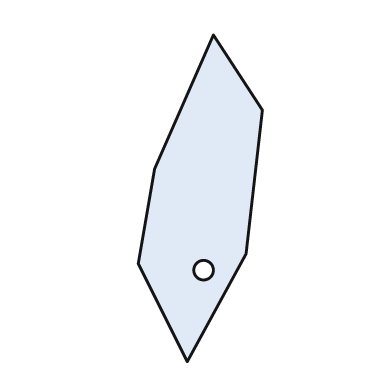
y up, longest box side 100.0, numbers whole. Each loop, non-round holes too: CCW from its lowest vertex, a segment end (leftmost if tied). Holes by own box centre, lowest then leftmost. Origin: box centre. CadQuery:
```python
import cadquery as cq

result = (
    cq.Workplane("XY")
    .moveTo(-4.0, -50.0)
    .lineTo(14.0, -17.0)
    .lineTo(19.0, 27.0)
    .lineTo(4.0, 50.0)
    .lineTo(-14.0, 9.0)
    .lineTo(-19.0, -20.0)
    .close()
    .moveTo(1.0, -22.0)
    .circle(3.0)
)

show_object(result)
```